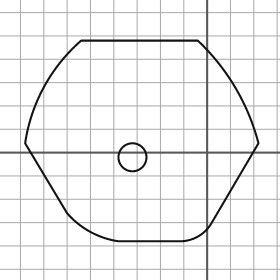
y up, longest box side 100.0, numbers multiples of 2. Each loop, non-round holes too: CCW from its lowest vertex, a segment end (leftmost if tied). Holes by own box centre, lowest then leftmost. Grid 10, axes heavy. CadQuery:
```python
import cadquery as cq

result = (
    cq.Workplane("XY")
    .moveTo(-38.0, -38.0)
    .lineTo(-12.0, -38.0)
    .threePointArc((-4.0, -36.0), (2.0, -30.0))
    .lineTo(22.0, 4.0)
    .threePointArc((12.0, 28.0), (-4.0, 48.0))
    .lineTo(-54.0, 48.0)
    .threePointArc((-70.0, 28.0), (-78.0, 4.0))
    .lineTo(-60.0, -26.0)
    .threePointArc((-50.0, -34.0), (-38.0, -38.0))
    .close()
    .moveTo(-32.0, -2.0)
    .circle(6.0)
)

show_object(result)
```